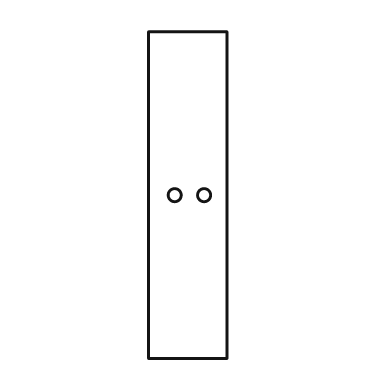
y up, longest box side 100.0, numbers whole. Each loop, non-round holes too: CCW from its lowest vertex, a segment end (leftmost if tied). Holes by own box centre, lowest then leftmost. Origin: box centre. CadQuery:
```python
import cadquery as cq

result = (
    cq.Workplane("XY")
    .moveTo(-12.0, -50.0)
    .lineTo(12.0, -50.0)
    .lineTo(12.0, 50.0)
    .lineTo(-12.0, 50.0)
    .close()
    .moveTo(-4.0, 0.0)
    .circle(2.0)
    .moveTo(5.0, 0.0)
    .circle(2.0)
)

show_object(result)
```